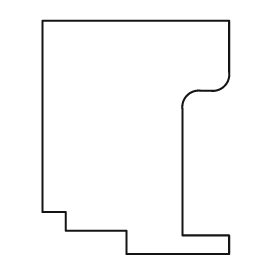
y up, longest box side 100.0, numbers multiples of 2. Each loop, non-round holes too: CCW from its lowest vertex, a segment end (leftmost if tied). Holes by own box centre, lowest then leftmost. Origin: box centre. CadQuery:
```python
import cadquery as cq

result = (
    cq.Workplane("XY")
    .moveTo(-4.0, -50.0)
    .lineTo(40.0, -50.0)
    .lineTo(40.0, -42.0)
    .lineTo(20.0, -42.0)
    .lineTo(20.0, 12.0)
    .threePointArc((22.0, 18.0), (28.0, 20.0))
    .lineTo(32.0, 20.0)
    .threePointArc((38.0, 22.0), (40.0, 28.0))
    .lineTo(40.0, 50.0)
    .lineTo(-40.0, 50.0)
    .lineTo(-40.0, -32.0)
    .lineTo(-30.0, -32.0)
    .lineTo(-30.0, -40.0)
    .lineTo(-4.0, -40.0)
    .close()
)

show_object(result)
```